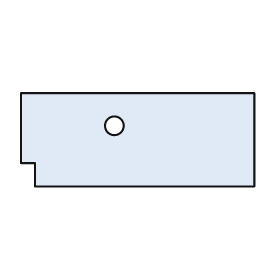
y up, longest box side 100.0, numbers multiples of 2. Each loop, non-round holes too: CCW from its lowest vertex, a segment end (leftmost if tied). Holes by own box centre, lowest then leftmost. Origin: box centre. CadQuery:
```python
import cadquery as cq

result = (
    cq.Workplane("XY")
    .moveTo(-44.0, -20.0)
    .lineTo(50.0, -20.0)
    .lineTo(50.0, 20.0)
    .lineTo(-50.0, 20.0)
    .lineTo(-50.0, -10.0)
    .lineTo(-44.0, -10.0)
    .close()
    .moveTo(-10.0, 6.0)
    .circle(4.0)
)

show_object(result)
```